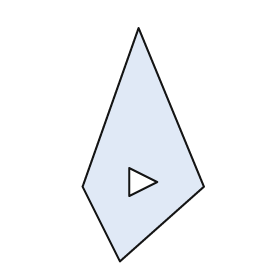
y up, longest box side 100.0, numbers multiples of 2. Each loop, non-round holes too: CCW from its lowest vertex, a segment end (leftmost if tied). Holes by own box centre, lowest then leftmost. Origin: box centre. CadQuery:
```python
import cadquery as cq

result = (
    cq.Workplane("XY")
    .moveTo(-10.0, -50.0)
    .lineTo(26.0, -18.0)
    .lineTo(-2.0, 50.0)
    .lineTo(-26.0, -18.0)
    .close()
    .moveTo(-6.0, -22.0)
    .lineTo(6.0, -16.0)
    .lineTo(-6.0, -10.0)
    .close()
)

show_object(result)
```